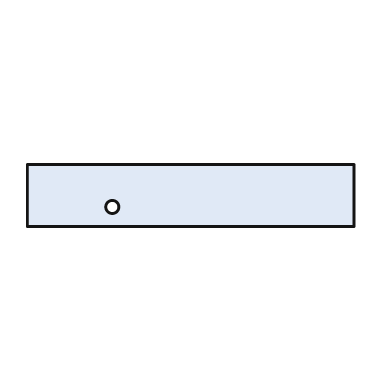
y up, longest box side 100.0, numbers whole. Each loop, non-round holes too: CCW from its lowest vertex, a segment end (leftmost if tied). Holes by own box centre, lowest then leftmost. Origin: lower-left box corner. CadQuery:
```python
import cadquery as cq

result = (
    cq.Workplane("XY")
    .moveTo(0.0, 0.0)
    .lineTo(100.0, 0.0)
    .lineTo(100.0, 19.0)
    .lineTo(0.0, 19.0)
    .close()
    .moveTo(26.0, 6.0)
    .circle(2.0)
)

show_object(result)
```